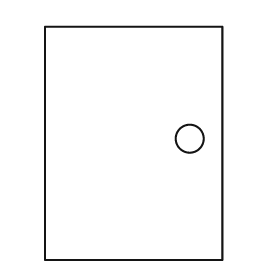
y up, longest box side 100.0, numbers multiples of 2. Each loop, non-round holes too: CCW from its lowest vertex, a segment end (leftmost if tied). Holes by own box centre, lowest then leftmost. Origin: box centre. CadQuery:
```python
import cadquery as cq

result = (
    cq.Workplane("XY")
    .moveTo(-38.0, -50.0)
    .lineTo(38.0, -50.0)
    .lineTo(38.0, 50.0)
    .lineTo(-38.0, 50.0)
    .close()
    .moveTo(24.0, 2.0)
    .circle(6.0)
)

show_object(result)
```